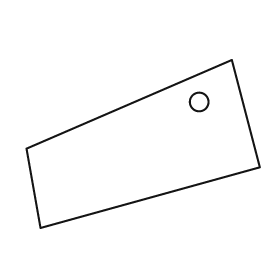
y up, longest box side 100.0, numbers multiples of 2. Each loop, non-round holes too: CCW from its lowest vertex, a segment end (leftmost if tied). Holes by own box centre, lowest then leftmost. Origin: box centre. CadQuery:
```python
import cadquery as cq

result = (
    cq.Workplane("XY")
    .moveTo(-44.0, -36.0)
    .lineTo(50.0, -10.0)
    .lineTo(38.0, 36.0)
    .lineTo(-50.0, -2.0)
    .close()
    .moveTo(24.0, 18.0)
    .circle(4.0)
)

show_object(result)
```